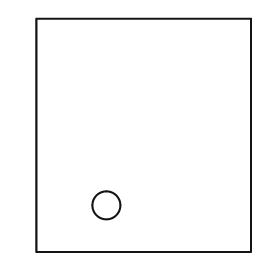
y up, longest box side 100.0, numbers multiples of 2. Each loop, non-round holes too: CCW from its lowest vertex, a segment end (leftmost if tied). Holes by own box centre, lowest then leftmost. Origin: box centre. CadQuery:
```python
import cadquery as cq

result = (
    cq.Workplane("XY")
    .moveTo(-46.0, -50.0)
    .lineTo(46.0, -50.0)
    .lineTo(46.0, 50.0)
    .lineTo(-46.0, 50.0)
    .close()
    .moveTo(-16.0, -30.0)
    .circle(6.0)
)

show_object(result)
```